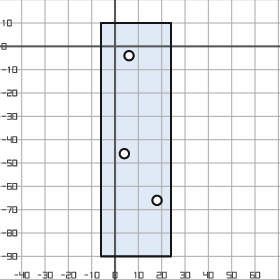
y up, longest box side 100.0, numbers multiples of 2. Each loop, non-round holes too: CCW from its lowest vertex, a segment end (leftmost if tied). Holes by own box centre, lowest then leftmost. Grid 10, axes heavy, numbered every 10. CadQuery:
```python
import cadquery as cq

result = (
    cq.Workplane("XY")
    .moveTo(-6.0, -90.0)
    .lineTo(24.0, -90.0)
    .lineTo(24.0, 10.0)
    .lineTo(-6.0, 10.0)
    .close()
    .moveTo(18.0, -66.0)
    .circle(2.0)
    .moveTo(4.0, -46.0)
    .circle(2.0)
    .moveTo(6.0, -4.0)
    .circle(2.0)
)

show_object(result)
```